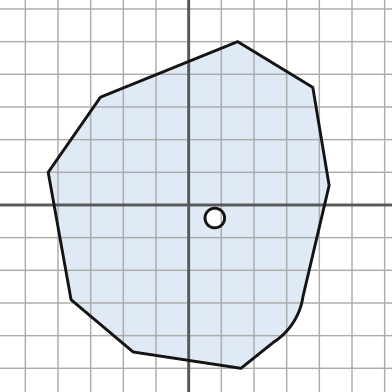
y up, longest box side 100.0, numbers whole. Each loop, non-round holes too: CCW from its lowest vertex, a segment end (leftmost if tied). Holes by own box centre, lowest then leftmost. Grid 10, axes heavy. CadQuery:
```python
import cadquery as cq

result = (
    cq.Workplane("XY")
    .moveTo(16.0, -50.0)
    .lineTo(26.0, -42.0)
    .threePointArc((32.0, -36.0), (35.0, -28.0))
    .lineTo(43.0, 6.0)
    .lineTo(38.0, 36.0)
    .lineTo(15.0, 50.0)
    .lineTo(-27.0, 33.0)
    .lineTo(-43.0, 10.0)
    .lineTo(-36.0, -29.0)
    .lineTo(-17.0, -45.0)
    .close()
    .moveTo(8.0, -4.0)
    .circle(3.0)
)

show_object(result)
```